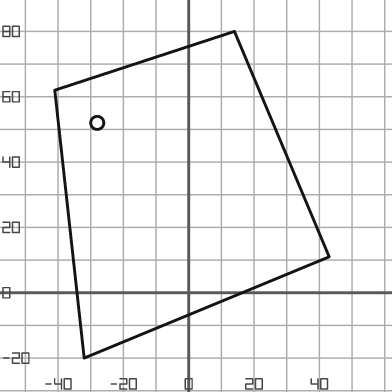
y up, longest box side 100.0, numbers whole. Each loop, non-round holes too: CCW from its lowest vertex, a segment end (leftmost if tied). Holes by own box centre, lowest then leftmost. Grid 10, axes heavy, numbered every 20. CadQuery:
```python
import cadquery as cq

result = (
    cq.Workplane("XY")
    .moveTo(-32.0, -20.0)
    .lineTo(43.0, 11.0)
    .lineTo(14.0, 80.0)
    .lineTo(-41.0, 62.0)
    .close()
    .moveTo(-28.0, 52.0)
    .circle(2.0)
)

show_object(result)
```